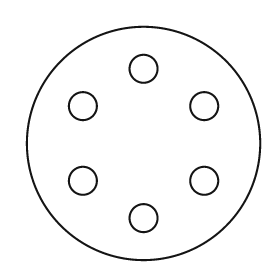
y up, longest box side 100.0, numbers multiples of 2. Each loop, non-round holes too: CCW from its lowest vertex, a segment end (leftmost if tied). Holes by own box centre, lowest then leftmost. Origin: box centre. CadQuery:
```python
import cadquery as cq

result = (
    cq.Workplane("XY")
    .moveTo(0.0, 0.0)
    .circle(50.0)
    .moveTo(0.0, -32.0)
    .circle(6.0)
    .moveTo(-26.0, -16.0)
    .circle(6.0)
    .moveTo(26.0, -16.0)
    .circle(6.0)
    .moveTo(-26.0, 16.0)
    .circle(6.0)
    .moveTo(26.0, 16.0)
    .circle(6.0)
    .moveTo(0.0, 32.0)
    .circle(6.0)
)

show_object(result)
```